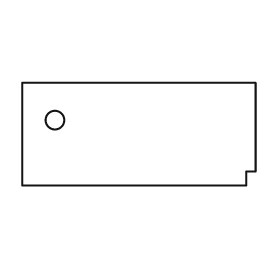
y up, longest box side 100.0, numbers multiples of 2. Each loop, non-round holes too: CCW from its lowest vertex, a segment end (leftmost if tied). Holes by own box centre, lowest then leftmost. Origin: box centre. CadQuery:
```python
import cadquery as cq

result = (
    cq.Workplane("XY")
    .moveTo(-50.0, -22.0)
    .lineTo(46.0, -22.0)
    .lineTo(46.0, -16.0)
    .lineTo(50.0, -16.0)
    .lineTo(50.0, 22.0)
    .lineTo(-50.0, 22.0)
    .close()
    .moveTo(-36.0, 6.0)
    .circle(4.0)
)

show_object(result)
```